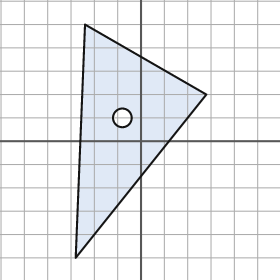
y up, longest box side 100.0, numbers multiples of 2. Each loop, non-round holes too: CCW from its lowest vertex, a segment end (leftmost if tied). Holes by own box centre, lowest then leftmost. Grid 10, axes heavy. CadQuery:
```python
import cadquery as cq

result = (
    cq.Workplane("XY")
    .moveTo(-28.0, -50.0)
    .lineTo(28.0, 20.0)
    .lineTo(-24.0, 50.0)
    .close()
    .moveTo(-8.0, 10.0)
    .circle(4.0)
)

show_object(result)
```